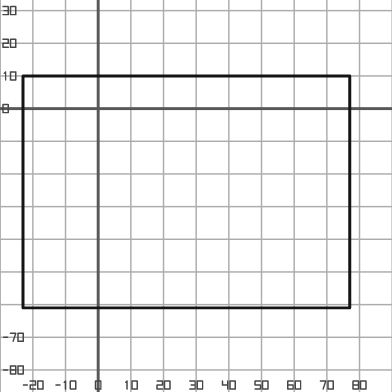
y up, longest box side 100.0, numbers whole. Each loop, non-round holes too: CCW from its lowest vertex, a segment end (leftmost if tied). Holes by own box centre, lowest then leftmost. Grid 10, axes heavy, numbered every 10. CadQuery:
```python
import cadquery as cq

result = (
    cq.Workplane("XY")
    .moveTo(-23.0, -61.0)
    .lineTo(77.0, -61.0)
    .lineTo(77.0, 10.0)
    .lineTo(-23.0, 10.0)
    .close()
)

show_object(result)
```